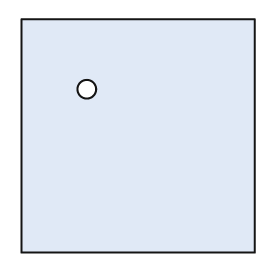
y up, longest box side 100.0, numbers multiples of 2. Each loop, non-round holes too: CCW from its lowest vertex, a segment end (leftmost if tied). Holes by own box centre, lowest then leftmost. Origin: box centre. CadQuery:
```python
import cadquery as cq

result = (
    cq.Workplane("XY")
    .moveTo(-50.0, -50.0)
    .lineTo(50.0, -50.0)
    .lineTo(50.0, 50.0)
    .lineTo(-50.0, 50.0)
    .close()
    .moveTo(-22.0, 20.0)
    .circle(4.0)
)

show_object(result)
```